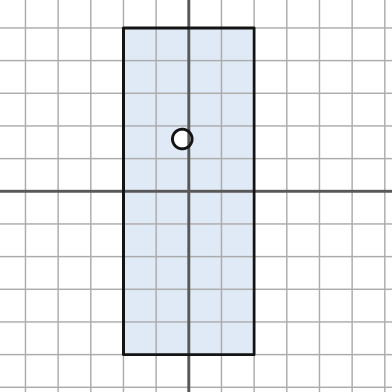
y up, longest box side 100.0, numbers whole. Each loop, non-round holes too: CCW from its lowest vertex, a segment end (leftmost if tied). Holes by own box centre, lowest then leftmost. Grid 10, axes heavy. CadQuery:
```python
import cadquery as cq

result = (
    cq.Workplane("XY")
    .moveTo(-20.0, -50.0)
    .lineTo(20.0, -50.0)
    .lineTo(20.0, 50.0)
    .lineTo(-20.0, 50.0)
    .close()
    .moveTo(-2.0, 16.0)
    .circle(3.0)
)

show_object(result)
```